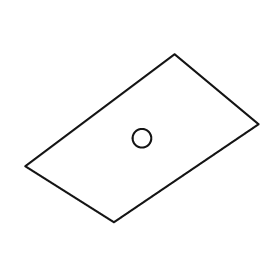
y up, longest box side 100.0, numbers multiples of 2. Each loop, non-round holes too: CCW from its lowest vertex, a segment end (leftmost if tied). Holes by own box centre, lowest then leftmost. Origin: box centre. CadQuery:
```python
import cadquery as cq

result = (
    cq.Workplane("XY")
    .moveTo(-12.0, -36.0)
    .lineTo(50.0, 6.0)
    .lineTo(14.0, 36.0)
    .lineTo(-50.0, -12.0)
    .close()
    .moveTo(0.0, 0.0)
    .circle(4.0)
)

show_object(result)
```